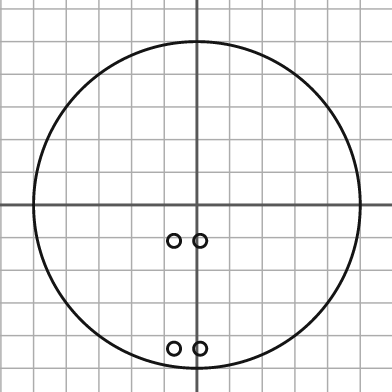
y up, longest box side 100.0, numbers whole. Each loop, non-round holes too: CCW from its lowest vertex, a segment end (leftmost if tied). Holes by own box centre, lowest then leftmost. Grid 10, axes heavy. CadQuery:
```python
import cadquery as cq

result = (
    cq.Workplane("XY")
    .moveTo(0.0, 0.0)
    .circle(50.0)
    .moveTo(-7.0, -44.0)
    .circle(2.0)
    .moveTo(1.0, -44.0)
    .circle(2.0)
    .moveTo(-7.0, -11.0)
    .circle(2.0)
    .moveTo(1.0, -11.0)
    .circle(2.0)
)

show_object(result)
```